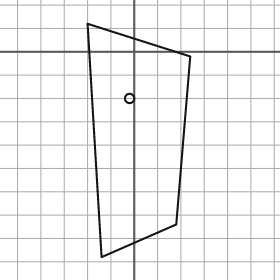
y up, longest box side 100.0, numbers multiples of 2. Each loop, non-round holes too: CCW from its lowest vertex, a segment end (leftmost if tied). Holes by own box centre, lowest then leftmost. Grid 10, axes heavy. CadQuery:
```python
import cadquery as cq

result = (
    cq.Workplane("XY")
    .moveTo(-14.0, -88.0)
    .lineTo(18.0, -74.0)
    .lineTo(24.0, -2.0)
    .lineTo(-20.0, 12.0)
    .close()
    .moveTo(-2.0, -20.0)
    .circle(2.0)
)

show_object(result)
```